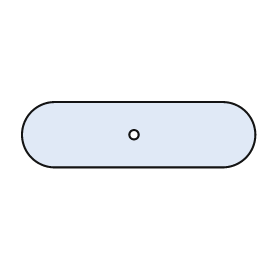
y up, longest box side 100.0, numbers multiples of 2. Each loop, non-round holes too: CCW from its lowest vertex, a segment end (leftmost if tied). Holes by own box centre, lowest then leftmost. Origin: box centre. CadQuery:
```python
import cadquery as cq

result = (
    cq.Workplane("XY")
    .moveTo(-36.0, -14.0)
    .lineTo(36.0, -14.0)
    .threePointArc((50.0, 0.0), (36.0, 14.0))
    .lineTo(-36.0, 14.0)
    .threePointArc((-50.0, 0.0), (-36.0, -14.0))
    .close()
    .moveTo(-2.0, 0.0)
    .circle(2.0)
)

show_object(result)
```